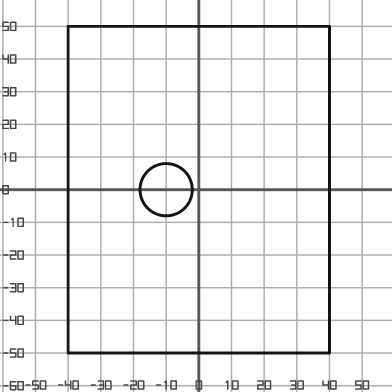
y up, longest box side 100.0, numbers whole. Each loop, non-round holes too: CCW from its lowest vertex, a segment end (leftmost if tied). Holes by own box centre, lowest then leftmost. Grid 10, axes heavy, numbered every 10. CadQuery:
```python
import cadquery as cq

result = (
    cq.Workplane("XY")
    .moveTo(-40.0, -50.0)
    .lineTo(40.0, -50.0)
    .lineTo(40.0, 50.0)
    .lineTo(-40.0, 50.0)
    .close()
    .moveTo(-10.0, 0.0)
    .circle(8.0)
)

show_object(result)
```